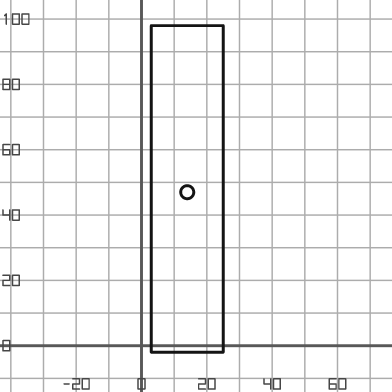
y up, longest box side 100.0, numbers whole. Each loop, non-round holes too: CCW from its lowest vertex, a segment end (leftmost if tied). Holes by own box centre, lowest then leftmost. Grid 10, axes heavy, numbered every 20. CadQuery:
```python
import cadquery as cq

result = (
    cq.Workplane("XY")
    .moveTo(3.0, -2.0)
    .lineTo(25.0, -2.0)
    .lineTo(25.0, 98.0)
    .lineTo(3.0, 98.0)
    .close()
    .moveTo(14.0, 47.0)
    .circle(2.0)
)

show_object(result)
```